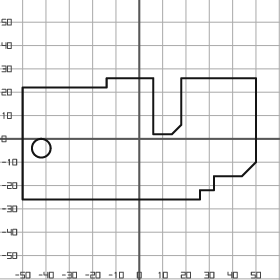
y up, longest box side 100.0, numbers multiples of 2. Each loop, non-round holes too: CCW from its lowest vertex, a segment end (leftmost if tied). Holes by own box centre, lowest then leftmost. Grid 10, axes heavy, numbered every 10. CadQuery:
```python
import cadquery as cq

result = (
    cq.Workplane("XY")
    .moveTo(-50.0, -26.0)
    .lineTo(26.0, -26.0)
    .lineTo(26.0, -22.0)
    .lineTo(32.0, -22.0)
    .lineTo(32.0, -16.0)
    .lineTo(44.0, -16.0)
    .lineTo(50.0, -10.0)
    .lineTo(50.0, 26.0)
    .lineTo(18.0, 26.0)
    .lineTo(18.0, 6.0)
    .lineTo(14.0, 2.0)
    .lineTo(6.0, 2.0)
    .lineTo(6.0, 26.0)
    .lineTo(-14.0, 26.0)
    .lineTo(-14.0, 22.0)
    .lineTo(-50.0, 22.0)
    .close()
    .moveTo(-42.0, -4.0)
    .circle(4.0)
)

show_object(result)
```